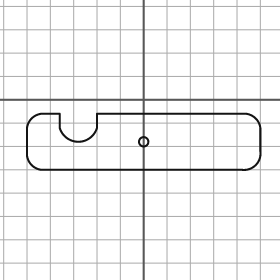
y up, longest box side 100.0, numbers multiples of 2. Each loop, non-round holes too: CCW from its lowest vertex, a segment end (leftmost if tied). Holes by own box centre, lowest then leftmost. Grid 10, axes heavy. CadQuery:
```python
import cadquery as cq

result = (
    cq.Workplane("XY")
    .moveTo(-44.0, -30.0)
    .lineTo(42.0, -30.0)
    .threePointArc((48.0, -28.0), (50.0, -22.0))
    .lineTo(50.0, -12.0)
    .threePointArc((48.0, -8.0), (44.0, -6.0))
    .lineTo(-20.0, -6.0)
    .lineTo(-20.0, -12.0)
    .threePointArc((-28.0, -18.0), (-36.0, -12.0))
    .lineTo(-36.0, -6.0)
    .lineTo(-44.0, -6.0)
    .threePointArc((-48.0, -8.0), (-50.0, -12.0))
    .lineTo(-50.0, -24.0)
    .threePointArc((-48.0, -28.0), (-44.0, -30.0))
    .close()
    .moveTo(0.0, -18.0)
    .circle(2.0)
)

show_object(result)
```